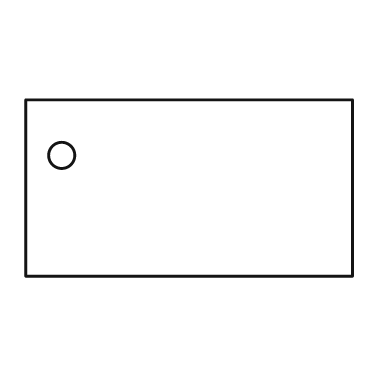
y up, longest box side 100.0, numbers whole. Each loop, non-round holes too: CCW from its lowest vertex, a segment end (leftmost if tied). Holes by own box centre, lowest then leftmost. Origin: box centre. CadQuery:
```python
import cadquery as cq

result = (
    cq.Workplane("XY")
    .moveTo(-50.0, -27.0)
    .lineTo(50.0, -27.0)
    .lineTo(50.0, 27.0)
    .lineTo(-50.0, 27.0)
    .close()
    .moveTo(-39.0, 10.0)
    .circle(4.0)
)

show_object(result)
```